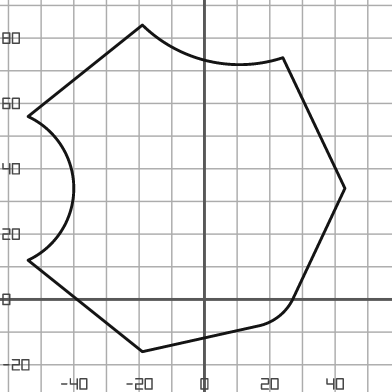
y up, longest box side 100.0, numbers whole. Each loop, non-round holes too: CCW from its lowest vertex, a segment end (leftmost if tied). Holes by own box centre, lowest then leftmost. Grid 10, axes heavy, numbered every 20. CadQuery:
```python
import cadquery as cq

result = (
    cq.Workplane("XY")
    .moveTo(-19.0, -16.0)
    .lineTo(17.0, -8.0)
    .threePointArc((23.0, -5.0), (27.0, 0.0))
    .lineTo(43.0, 34.0)
    .lineTo(24.0, 74.0)
    .threePointArc((1.0, 73.0), (-19.0, 84.0))
    .lineTo(-54.0, 56.0)
    .threePointArc((-40.0, 34.0), (-54.0, 12.0))
    .close()
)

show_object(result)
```